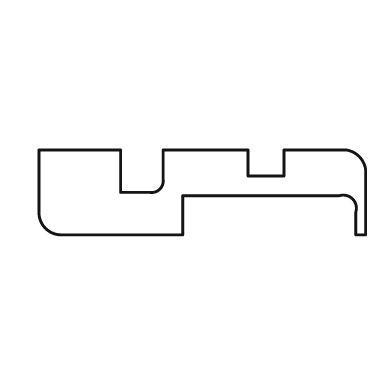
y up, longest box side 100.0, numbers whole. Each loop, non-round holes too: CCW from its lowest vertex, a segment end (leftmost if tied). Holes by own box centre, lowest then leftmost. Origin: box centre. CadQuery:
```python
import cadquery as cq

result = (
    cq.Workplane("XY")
    .moveTo(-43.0, -13.0)
    .lineTo(-6.0, -13.0)
    .lineTo(-6.0, -1.0)
    .lineTo(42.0, -1.0)
    .threePointArc((46.0, -2.0), (47.0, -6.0))
    .lineTo(47.0, -13.0)
    .lineTo(50.0, -13.0)
    .lineTo(50.0, 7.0)
    .threePointArc((48.0, 11.0), (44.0, 13.0))
    .lineTo(25.0, 13.0)
    .lineTo(25.0, 5.0)
    .lineTo(14.0, 5.0)
    .lineTo(14.0, 13.0)
    .lineTo(-12.0, 13.0)
    .lineTo(-12.0, 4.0)
    .threePointArc((-13.0, 1.0), (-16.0, 0.0))
    .lineTo(-25.0, 0.0)
    .lineTo(-25.0, 13.0)
    .lineTo(-50.0, 13.0)
    .lineTo(-50.0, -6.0)
    .threePointArc((-48.0, -11.0), (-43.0, -13.0))
    .close()
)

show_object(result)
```